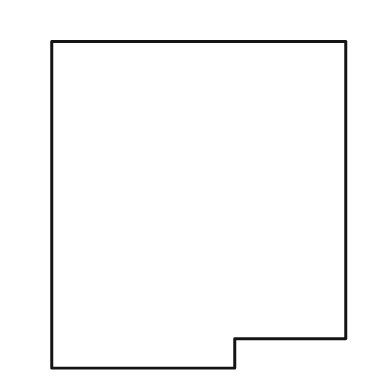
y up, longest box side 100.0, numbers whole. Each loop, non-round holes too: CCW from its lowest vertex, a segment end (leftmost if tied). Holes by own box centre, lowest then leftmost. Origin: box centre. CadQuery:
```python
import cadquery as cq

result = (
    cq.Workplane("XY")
    .moveTo(-45.0, -50.0)
    .lineTo(11.0, -50.0)
    .lineTo(11.0, -41.0)
    .lineTo(45.0, -41.0)
    .lineTo(45.0, 50.0)
    .lineTo(-45.0, 50.0)
    .close()
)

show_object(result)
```